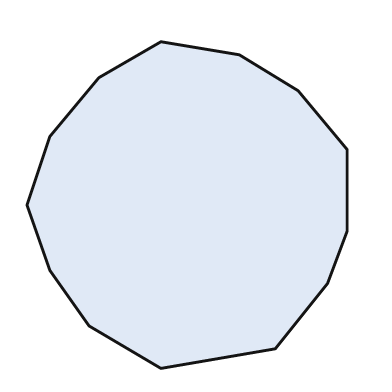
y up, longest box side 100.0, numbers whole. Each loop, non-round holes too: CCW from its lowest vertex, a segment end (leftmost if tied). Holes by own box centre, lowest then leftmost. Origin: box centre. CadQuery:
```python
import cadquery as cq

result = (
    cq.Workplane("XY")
    .moveTo(-8.0, -50.0)
    .lineTo(27.0, -44.0)
    .lineTo(43.0, -24.0)
    .lineTo(49.0, -8.0)
    .lineTo(49.0, 17.0)
    .lineTo(34.0, 35.0)
    .lineTo(16.0, 46.0)
    .lineTo(-8.0, 50.0)
    .lineTo(-27.0, 39.0)
    .lineTo(-42.0, 21.0)
    .lineTo(-49.0, 0.0)
    .lineTo(-42.0, -20.0)
    .lineTo(-30.0, -37.0)
    .close()
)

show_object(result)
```